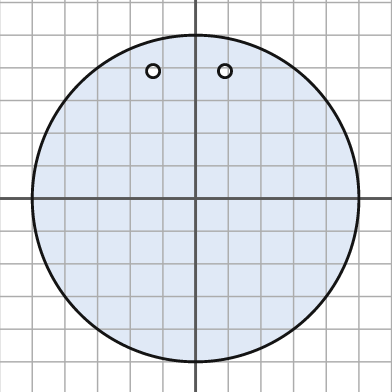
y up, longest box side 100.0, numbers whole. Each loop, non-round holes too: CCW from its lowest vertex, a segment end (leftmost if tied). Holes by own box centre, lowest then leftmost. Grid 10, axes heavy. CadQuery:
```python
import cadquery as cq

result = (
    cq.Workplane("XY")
    .moveTo(0.0, 0.0)
    .circle(50.0)
    .moveTo(-13.0, 39.0)
    .circle(2.0)
    .moveTo(9.0, 39.0)
    .circle(2.0)
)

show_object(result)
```